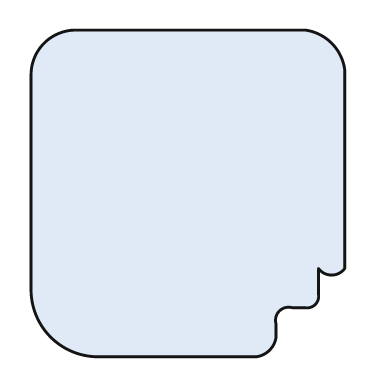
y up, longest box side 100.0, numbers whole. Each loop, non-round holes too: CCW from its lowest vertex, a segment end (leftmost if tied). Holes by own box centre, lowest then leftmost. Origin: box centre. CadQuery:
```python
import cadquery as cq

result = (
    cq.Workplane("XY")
    .moveTo(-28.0, -50.0)
    .lineTo(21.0, -50.0)
    .threePointArc((25.0, -48.0), (27.0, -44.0))
    .lineTo(27.0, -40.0)
    .threePointArc((28.0, -36.0), (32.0, -35.0))
    .lineTo(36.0, -35.0)
    .threePointArc((39.0, -34.0), (40.0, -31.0))
    .lineTo(40.0, -23.0)
    .threePointArc((44.0, -25.0), (48.0, -23.0))
    .lineTo(48.0, 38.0)
    .threePointArc((44.0, 46.0), (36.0, 50.0))
    .lineTo(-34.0, 50.0)
    .threePointArc((-44.0, 46.0), (-48.0, 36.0))
    .lineTo(-48.0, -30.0)
    .threePointArc((-42.0, -44.0), (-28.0, -50.0))
    .close()
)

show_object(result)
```